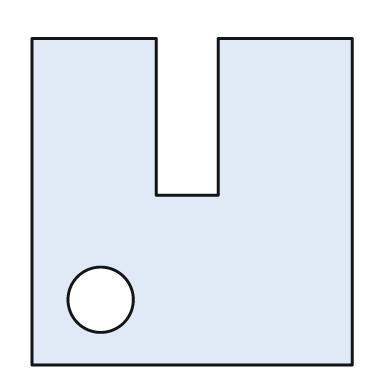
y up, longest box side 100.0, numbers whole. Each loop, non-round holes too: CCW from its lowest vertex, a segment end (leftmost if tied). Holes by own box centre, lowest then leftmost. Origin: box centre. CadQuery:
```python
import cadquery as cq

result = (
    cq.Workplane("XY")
    .moveTo(-49.0, -50.0)
    .lineTo(49.0, -50.0)
    .lineTo(49.0, 50.0)
    .lineTo(8.0, 50.0)
    .lineTo(8.0, 2.0)
    .lineTo(-11.0, 2.0)
    .lineTo(-11.0, 50.0)
    .lineTo(-49.0, 50.0)
    .close()
    .moveTo(-28.0, -30.0)
    .circle(10.0)
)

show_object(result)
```